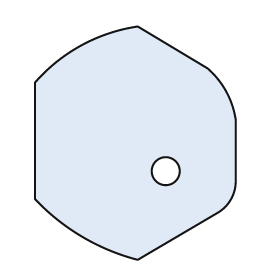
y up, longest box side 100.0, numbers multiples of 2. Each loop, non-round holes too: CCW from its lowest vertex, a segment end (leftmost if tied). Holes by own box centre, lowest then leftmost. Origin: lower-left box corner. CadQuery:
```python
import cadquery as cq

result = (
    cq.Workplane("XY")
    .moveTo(44.0, 0.0)
    .lineTo(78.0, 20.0)
    .threePointArc((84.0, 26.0), (86.0, 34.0))
    .lineTo(86.0, 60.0)
    .threePointArc((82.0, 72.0), (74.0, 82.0))
    .lineTo(44.0, 100.0)
    .threePointArc((20.0, 92.0), (0.0, 76.0))
    .lineTo(0.0, 26.0)
    .threePointArc((20.0, 10.0), (44.0, 0.0))
    .close()
    .moveTo(56.0, 38.0)
    .circle(6.0)
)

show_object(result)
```